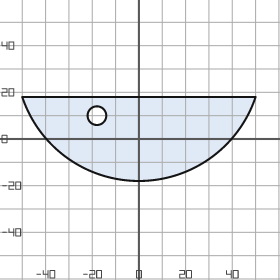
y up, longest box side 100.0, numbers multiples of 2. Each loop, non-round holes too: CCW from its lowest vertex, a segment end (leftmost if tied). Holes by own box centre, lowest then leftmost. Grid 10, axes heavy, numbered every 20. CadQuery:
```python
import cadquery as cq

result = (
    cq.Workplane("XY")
    .moveTo(-50.0, 18.0)
    .threePointArc((0.0, -18.0), (50.0, 18.0))
    .close()
    .moveTo(-18.0, 10.0)
    .circle(4.0)
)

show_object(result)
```